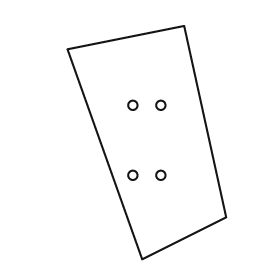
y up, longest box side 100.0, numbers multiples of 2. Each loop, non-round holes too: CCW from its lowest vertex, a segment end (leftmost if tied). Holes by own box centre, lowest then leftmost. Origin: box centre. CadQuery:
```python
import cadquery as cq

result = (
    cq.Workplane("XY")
    .moveTo(-2.0, -50.0)
    .lineTo(34.0, -32.0)
    .lineTo(16.0, 50.0)
    .lineTo(-34.0, 40.0)
    .close()
    .moveTo(-6.0, -14.0)
    .circle(2.0)
    .moveTo(6.0, -14.0)
    .circle(2.0)
    .moveTo(-6.0, 16.0)
    .circle(2.0)
    .moveTo(6.0, 16.0)
    .circle(2.0)
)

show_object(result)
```